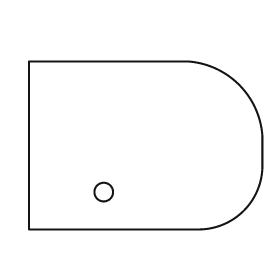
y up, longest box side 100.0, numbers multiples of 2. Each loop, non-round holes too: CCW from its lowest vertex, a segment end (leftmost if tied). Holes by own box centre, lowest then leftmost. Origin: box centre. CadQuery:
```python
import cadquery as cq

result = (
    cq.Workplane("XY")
    .moveTo(-50.0, -36.0)
    .lineTo(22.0, -36.0)
    .threePointArc((42.0, -28.0), (50.0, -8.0))
    .lineTo(50.0, 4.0)
    .threePointArc((40.0, 26.0), (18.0, 36.0))
    .lineTo(-50.0, 36.0)
    .close()
    .moveTo(-18.0, -20.0)
    .circle(4.0)
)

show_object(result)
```